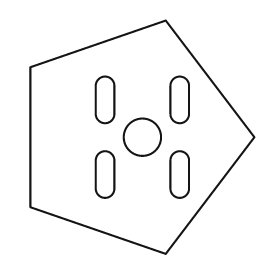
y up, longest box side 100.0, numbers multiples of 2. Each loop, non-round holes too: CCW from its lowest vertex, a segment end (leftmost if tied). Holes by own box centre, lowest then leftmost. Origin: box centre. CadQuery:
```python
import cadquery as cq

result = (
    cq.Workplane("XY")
    .moveTo(10.0, -50.0)
    .lineTo(48.0, 0.0)
    .lineTo(10.0, 50.0)
    .lineTo(-48.0, 30.0)
    .lineTo(-48.0, -30.0)
    .close()
    .moveTo(-20.0, -22.0)
    .threePointArc((-16.0, -26.0), (-12.0, -22.0))
    .lineTo(-12.0, -10.0)
    .threePointArc((-16.0, -6.0), (-20.0, -10.0))
    .close()
    .moveTo(12.0, -22.0)
    .threePointArc((16.0, -26.0), (20.0, -22.0))
    .lineTo(20.0, -10.0)
    .threePointArc((16.0, -6.0), (12.0, -10.0))
    .close()
    .moveTo(0.0, 0.0)
    .circle(8.0)
    .moveTo(-20.0, 10.0)
    .threePointArc((-16.0, 6.0), (-12.0, 10.0))
    .lineTo(-12.0, 22.0)
    .threePointArc((-16.0, 26.0), (-20.0, 22.0))
    .close()
    .moveTo(12.0, 10.0)
    .threePointArc((16.0, 6.0), (20.0, 10.0))
    .lineTo(20.0, 22.0)
    .threePointArc((16.0, 26.0), (12.0, 22.0))
    .close()
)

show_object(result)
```